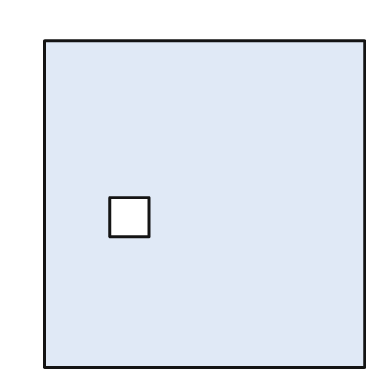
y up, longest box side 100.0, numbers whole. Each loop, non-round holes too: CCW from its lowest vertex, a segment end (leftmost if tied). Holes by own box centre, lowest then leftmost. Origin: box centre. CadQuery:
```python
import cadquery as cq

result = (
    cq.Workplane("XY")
    .moveTo(-49.0, -50.0)
    .lineTo(49.0, -50.0)
    .lineTo(49.0, 50.0)
    .lineTo(-49.0, 50.0)
    .close()
    .moveTo(-29.0, -10.0)
    .lineTo(-17.0, -10.0)
    .lineTo(-17.0, 2.0)
    .lineTo(-29.0, 2.0)
    .close()
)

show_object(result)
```